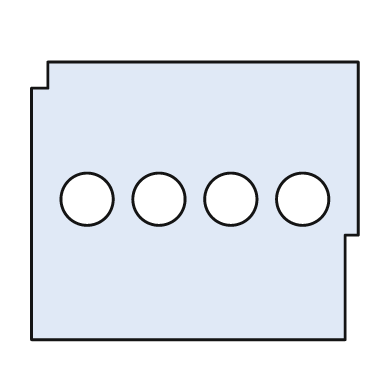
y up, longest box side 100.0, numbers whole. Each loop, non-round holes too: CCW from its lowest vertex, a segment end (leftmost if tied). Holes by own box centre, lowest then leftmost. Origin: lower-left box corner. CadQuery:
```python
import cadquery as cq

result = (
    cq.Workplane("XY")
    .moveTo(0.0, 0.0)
    .lineTo(96.0, 0.0)
    .lineTo(96.0, 32.0)
    .lineTo(100.0, 32.0)
    .lineTo(100.0, 85.0)
    .lineTo(5.0, 85.0)
    .lineTo(5.0, 77.0)
    .lineTo(0.0, 77.0)
    .close()
    .moveTo(17.0, 43.0)
    .circle(8.0)
    .moveTo(39.0, 43.0)
    .circle(8.0)
    .moveTo(61.0, 43.0)
    .circle(8.0)
    .moveTo(83.0, 43.0)
    .circle(8.0)
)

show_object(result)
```